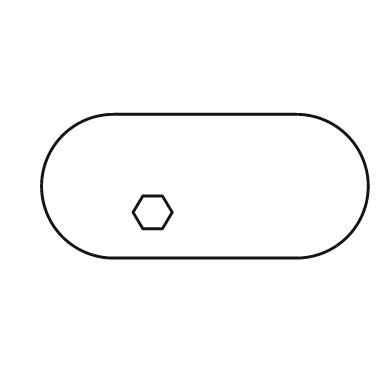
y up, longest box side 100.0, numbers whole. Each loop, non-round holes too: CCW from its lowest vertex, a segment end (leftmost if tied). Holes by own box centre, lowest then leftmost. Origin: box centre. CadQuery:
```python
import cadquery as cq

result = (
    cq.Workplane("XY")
    .moveTo(-28.0, -22.0)
    .lineTo(28.0, -22.0)
    .threePointArc((50.0, 0.0), (28.0, 22.0))
    .lineTo(-28.0, 22.0)
    .threePointArc((-50.0, 0.0), (-28.0, -22.0))
    .close()
    .moveTo(-19.0, -13.0)
    .lineTo(-13.0, -13.0)
    .lineTo(-10.0, -8.0)
    .lineTo(-13.0, -3.0)
    .lineTo(-19.0, -3.0)
    .lineTo(-22.0, -8.0)
    .close()
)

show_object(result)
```